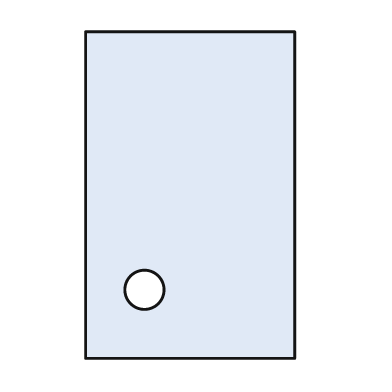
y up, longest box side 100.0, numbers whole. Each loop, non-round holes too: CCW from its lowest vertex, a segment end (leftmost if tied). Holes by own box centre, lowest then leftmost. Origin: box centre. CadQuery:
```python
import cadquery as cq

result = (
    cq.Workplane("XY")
    .moveTo(-32.0, -50.0)
    .lineTo(32.0, -50.0)
    .lineTo(32.0, 50.0)
    .lineTo(-32.0, 50.0)
    .close()
    .moveTo(-14.0, -29.0)
    .circle(6.0)
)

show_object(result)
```